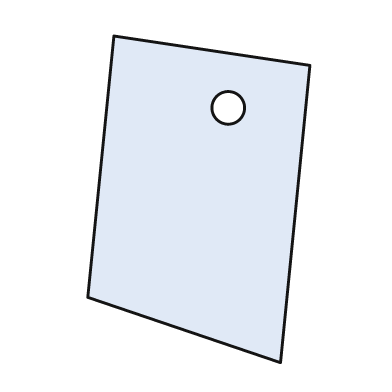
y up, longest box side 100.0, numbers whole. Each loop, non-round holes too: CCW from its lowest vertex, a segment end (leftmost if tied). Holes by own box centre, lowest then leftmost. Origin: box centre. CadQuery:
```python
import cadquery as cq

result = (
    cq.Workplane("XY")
    .moveTo(25.0, -50.0)
    .lineTo(34.0, 41.0)
    .lineTo(-26.0, 50.0)
    .lineTo(-34.0, -30.0)
    .close()
    .moveTo(9.0, 28.0)
    .circle(5.0)
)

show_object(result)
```